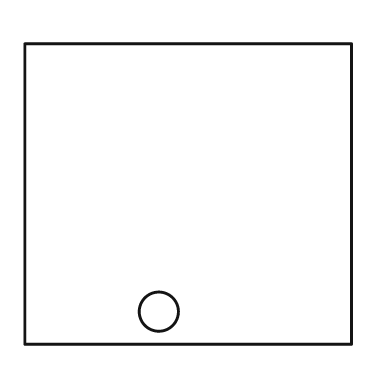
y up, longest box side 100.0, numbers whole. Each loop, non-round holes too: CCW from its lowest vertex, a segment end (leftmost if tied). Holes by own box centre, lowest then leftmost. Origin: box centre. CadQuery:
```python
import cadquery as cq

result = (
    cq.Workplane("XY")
    .moveTo(-50.0, -46.0)
    .lineTo(50.0, -46.0)
    .lineTo(50.0, 46.0)
    .lineTo(-50.0, 46.0)
    .close()
    .moveTo(-9.0, -36.0)
    .circle(6.0)
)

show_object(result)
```